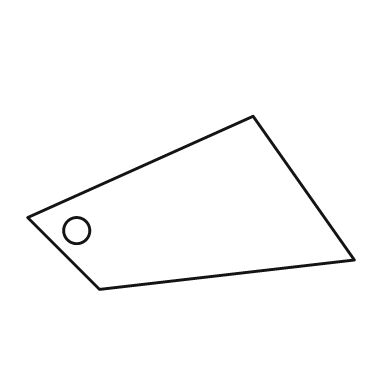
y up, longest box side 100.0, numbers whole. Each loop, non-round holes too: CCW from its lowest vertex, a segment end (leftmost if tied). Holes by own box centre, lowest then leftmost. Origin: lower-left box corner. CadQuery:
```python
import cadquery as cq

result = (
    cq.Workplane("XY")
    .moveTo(22.0, 0.0)
    .lineTo(100.0, 9.0)
    .lineTo(69.0, 53.0)
    .lineTo(0.0, 22.0)
    .close()
    .moveTo(15.0, 18.0)
    .circle(4.0)
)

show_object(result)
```